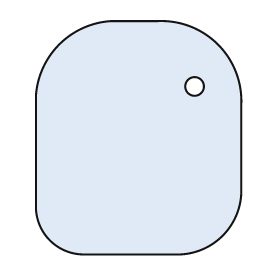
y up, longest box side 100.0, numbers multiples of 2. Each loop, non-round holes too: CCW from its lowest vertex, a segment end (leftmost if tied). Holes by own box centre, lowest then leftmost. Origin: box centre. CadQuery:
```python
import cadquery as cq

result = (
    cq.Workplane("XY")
    .moveTo(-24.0, -50.0)
    .lineTo(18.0, -50.0)
    .threePointArc((36.0, -42.0), (44.0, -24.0))
    .lineTo(44.0, 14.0)
    .threePointArc((34.0, 40.0), (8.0, 50.0))
    .lineTo(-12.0, 50.0)
    .threePointArc((-34.0, 40.0), (-44.0, 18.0))
    .lineTo(-44.0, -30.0)
    .threePointArc((-38.0, -44.0), (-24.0, -50.0))
    .close()
    .moveTo(24.0, 22.0)
    .circle(4.0)
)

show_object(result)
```